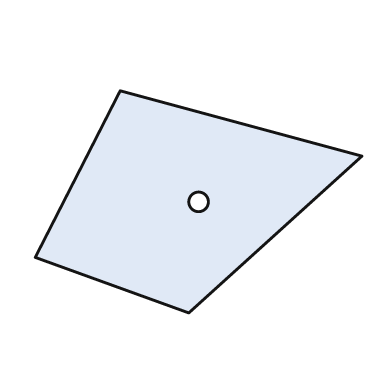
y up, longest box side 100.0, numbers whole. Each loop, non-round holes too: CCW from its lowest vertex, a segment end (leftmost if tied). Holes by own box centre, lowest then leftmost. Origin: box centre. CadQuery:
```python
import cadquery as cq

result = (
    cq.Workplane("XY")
    .moveTo(-3.0, -34.0)
    .lineTo(50.0, 14.0)
    .lineTo(-24.0, 34.0)
    .lineTo(-50.0, -17.0)
    .close()
    .moveTo(0.0, 0.0)
    .circle(3.0)
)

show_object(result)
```